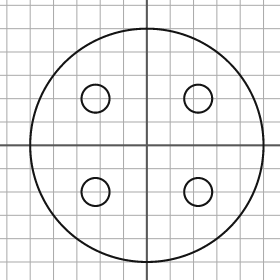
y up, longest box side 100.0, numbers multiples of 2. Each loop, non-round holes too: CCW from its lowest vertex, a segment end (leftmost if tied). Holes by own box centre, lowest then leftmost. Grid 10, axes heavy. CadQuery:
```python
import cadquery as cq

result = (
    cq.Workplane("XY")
    .moveTo(0.0, 0.0)
    .circle(50.0)
    .moveTo(-22.0, -20.0)
    .circle(6.0)
    .moveTo(22.0, -20.0)
    .circle(6.0)
    .moveTo(-22.0, 20.0)
    .circle(6.0)
    .moveTo(22.0, 20.0)
    .circle(6.0)
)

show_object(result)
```